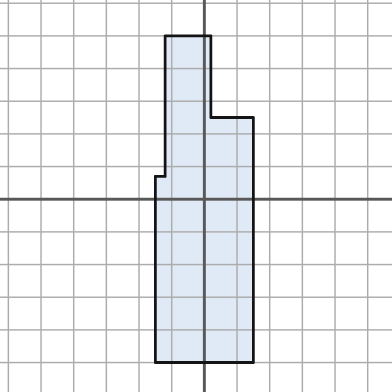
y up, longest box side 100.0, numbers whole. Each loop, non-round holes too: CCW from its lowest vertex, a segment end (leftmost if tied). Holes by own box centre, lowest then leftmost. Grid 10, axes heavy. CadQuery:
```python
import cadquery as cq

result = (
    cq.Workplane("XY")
    .moveTo(-15.0, -50.0)
    .lineTo(15.0, -50.0)
    .lineTo(15.0, 25.0)
    .lineTo(2.0, 25.0)
    .lineTo(2.0, 50.0)
    .lineTo(-12.0, 50.0)
    .lineTo(-12.0, 7.0)
    .lineTo(-15.0, 7.0)
    .close()
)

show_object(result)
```